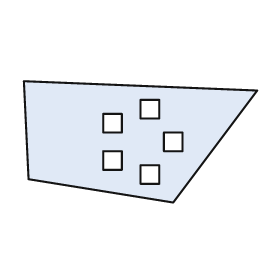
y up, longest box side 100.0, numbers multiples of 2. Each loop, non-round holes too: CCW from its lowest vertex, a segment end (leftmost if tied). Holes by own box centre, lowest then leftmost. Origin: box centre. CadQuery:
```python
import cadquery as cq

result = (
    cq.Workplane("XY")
    .moveTo(14.0, -26.0)
    .lineTo(50.0, 22.0)
    .lineTo(-50.0, 26.0)
    .lineTo(-48.0, -16.0)
    .close()
    .moveTo(0.0, -18.0)
    .lineTo(8.0, -18.0)
    .lineTo(8.0, -10.0)
    .lineTo(0.0, -10.0)
    .close()
    .moveTo(-16.0, -12.0)
    .lineTo(-8.0, -12.0)
    .lineTo(-8.0, -4.0)
    .lineTo(-16.0, -4.0)
    .close()
    .moveTo(10.0, -4.0)
    .lineTo(18.0, -4.0)
    .lineTo(18.0, 4.0)
    .lineTo(10.0, 4.0)
    .close()
    .moveTo(-16.0, 4.0)
    .lineTo(-8.0, 4.0)
    .lineTo(-8.0, 12.0)
    .lineTo(-16.0, 12.0)
    .close()
    .moveTo(0.0, 10.0)
    .lineTo(8.0, 10.0)
    .lineTo(8.0, 18.0)
    .lineTo(0.0, 18.0)
    .close()
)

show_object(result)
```